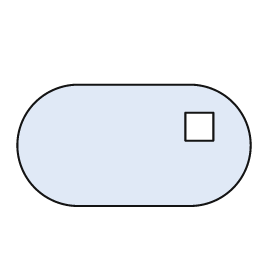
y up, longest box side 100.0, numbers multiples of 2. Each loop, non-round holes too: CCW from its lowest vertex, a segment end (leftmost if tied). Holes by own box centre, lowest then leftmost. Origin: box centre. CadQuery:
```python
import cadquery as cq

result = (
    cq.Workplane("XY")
    .moveTo(-24.0, -26.0)
    .lineTo(24.0, -26.0)
    .threePointArc((50.0, 0.0), (24.0, 26.0))
    .lineTo(-24.0, 26.0)
    .threePointArc((-50.0, 0.0), (-24.0, -26.0))
    .close()
    .moveTo(22.0, 2.0)
    .lineTo(34.0, 2.0)
    .lineTo(34.0, 14.0)
    .lineTo(22.0, 14.0)
    .close()
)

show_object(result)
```